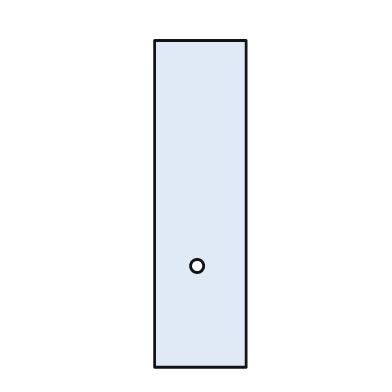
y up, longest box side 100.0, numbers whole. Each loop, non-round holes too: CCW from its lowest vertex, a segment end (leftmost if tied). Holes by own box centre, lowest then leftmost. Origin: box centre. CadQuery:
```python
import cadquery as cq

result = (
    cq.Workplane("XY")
    .moveTo(-14.0, -50.0)
    .lineTo(14.0, -50.0)
    .lineTo(14.0, 50.0)
    .lineTo(-14.0, 50.0)
    .close()
    .moveTo(-1.0, -19.0)
    .circle(2.0)
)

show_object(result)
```